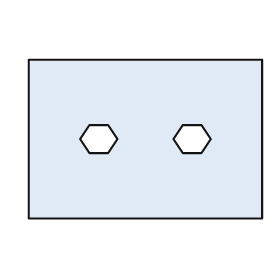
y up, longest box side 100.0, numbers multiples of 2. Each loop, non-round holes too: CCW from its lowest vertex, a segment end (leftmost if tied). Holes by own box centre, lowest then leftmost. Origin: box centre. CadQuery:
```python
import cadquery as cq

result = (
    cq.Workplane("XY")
    .moveTo(-50.0, -34.0)
    .lineTo(50.0, -34.0)
    .lineTo(50.0, 34.0)
    .lineTo(-50.0, 34.0)
    .close()
    .moveTo(-24.0, -6.0)
    .lineTo(-16.0, -6.0)
    .lineTo(-12.0, 0.0)
    .lineTo(-16.0, 6.0)
    .lineTo(-24.0, 6.0)
    .lineTo(-28.0, 0.0)
    .close()
    .moveTo(16.0, -6.0)
    .lineTo(24.0, -6.0)
    .lineTo(28.0, 0.0)
    .lineTo(24.0, 6.0)
    .lineTo(16.0, 6.0)
    .lineTo(12.0, 0.0)
    .close()
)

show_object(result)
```